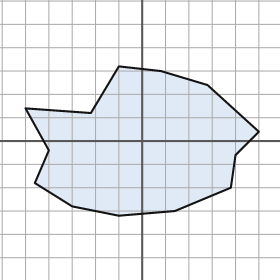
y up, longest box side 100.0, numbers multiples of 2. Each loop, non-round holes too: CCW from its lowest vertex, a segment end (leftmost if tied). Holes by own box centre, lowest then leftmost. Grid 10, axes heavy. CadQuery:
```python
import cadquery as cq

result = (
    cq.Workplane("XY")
    .moveTo(-10.0, -32.0)
    .lineTo(14.0, -30.0)
    .lineTo(38.0, -20.0)
    .lineTo(40.0, -6.0)
    .lineTo(50.0, 4.0)
    .lineTo(28.0, 24.0)
    .lineTo(8.0, 30.0)
    .lineTo(-10.0, 32.0)
    .lineTo(-22.0, 12.0)
    .lineTo(-50.0, 14.0)
    .lineTo(-40.0, -4.0)
    .lineTo(-46.0, -18.0)
    .lineTo(-30.0, -28.0)
    .close()
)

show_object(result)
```